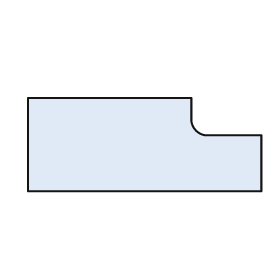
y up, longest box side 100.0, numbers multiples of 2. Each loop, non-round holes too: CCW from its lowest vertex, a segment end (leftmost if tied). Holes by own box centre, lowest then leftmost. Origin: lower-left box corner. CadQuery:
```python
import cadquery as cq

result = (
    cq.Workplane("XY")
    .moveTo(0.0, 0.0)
    .lineTo(100.0, 0.0)
    .lineTo(100.0, 24.0)
    .lineTo(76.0, 24.0)
    .threePointArc((72.0, 26.0), (70.0, 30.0))
    .lineTo(70.0, 40.0)
    .lineTo(0.0, 40.0)
    .close()
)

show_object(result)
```